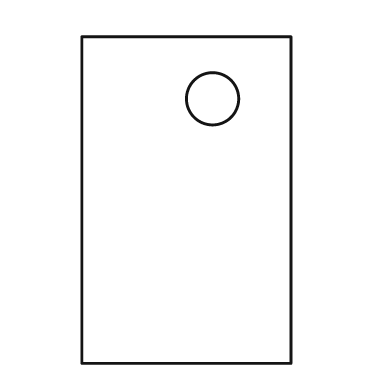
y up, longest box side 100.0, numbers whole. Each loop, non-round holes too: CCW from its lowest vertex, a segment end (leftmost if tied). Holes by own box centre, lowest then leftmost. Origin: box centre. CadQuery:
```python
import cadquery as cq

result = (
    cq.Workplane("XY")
    .moveTo(-32.0, -50.0)
    .lineTo(32.0, -50.0)
    .lineTo(32.0, 50.0)
    .lineTo(-32.0, 50.0)
    .close()
    .moveTo(8.0, 31.0)
    .circle(8.0)
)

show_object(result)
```